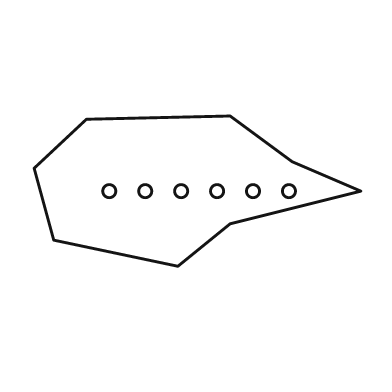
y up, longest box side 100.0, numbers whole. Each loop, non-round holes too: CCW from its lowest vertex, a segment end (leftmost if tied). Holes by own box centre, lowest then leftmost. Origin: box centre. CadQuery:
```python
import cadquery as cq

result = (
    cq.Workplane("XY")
    .moveTo(-6.0, -23.0)
    .lineTo(10.0, -10.0)
    .lineTo(50.0, 0.0)
    .lineTo(29.0, 9.0)
    .lineTo(10.0, 23.0)
    .lineTo(-34.0, 22.0)
    .lineTo(-50.0, 7.0)
    .lineTo(-44.0, -15.0)
    .close()
    .moveTo(-27.0, 0.0)
    .circle(2.0)
    .moveTo(-16.0, 0.0)
    .circle(2.0)
    .moveTo(-5.0, 0.0)
    .circle(2.0)
    .moveTo(6.0, 0.0)
    .circle(2.0)
    .moveTo(17.0, 0.0)
    .circle(2.0)
    .moveTo(28.0, 0.0)
    .circle(2.0)
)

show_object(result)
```